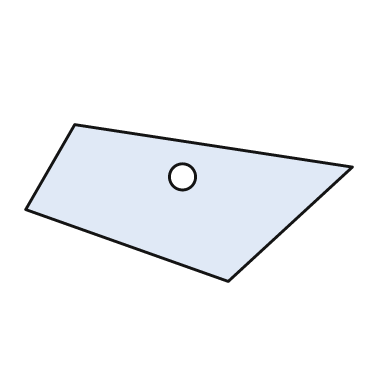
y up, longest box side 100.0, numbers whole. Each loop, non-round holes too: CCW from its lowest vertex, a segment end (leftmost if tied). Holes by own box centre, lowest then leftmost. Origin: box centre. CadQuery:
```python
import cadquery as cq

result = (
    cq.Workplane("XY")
    .moveTo(12.0, -24.0)
    .lineTo(50.0, 11.0)
    .lineTo(-35.0, 24.0)
    .lineTo(-50.0, -2.0)
    .close()
    .moveTo(-2.0, 8.0)
    .circle(4.0)
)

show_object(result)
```